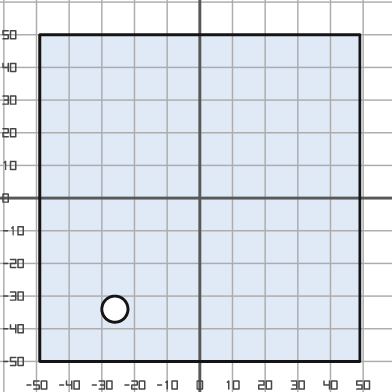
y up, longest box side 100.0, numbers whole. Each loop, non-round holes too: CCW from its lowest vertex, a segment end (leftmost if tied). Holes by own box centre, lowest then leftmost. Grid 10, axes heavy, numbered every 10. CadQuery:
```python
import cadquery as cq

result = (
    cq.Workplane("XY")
    .moveTo(-49.0, -50.0)
    .lineTo(49.0, -50.0)
    .lineTo(49.0, 50.0)
    .lineTo(-49.0, 50.0)
    .close()
    .moveTo(-26.0, -34.0)
    .circle(4.0)
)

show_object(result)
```